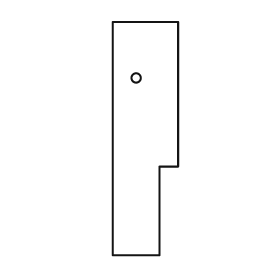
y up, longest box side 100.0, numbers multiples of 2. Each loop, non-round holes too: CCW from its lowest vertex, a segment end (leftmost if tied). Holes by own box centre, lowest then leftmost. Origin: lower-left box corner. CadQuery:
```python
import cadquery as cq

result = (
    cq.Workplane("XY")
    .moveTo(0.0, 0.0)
    .lineTo(20.0, 0.0)
    .lineTo(20.0, 38.0)
    .lineTo(28.0, 38.0)
    .lineTo(28.0, 100.0)
    .lineTo(0.0, 100.0)
    .close()
    .moveTo(10.0, 76.0)
    .circle(2.0)
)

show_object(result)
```